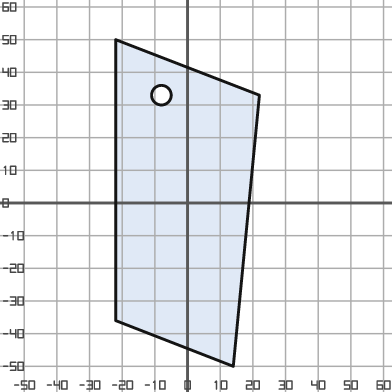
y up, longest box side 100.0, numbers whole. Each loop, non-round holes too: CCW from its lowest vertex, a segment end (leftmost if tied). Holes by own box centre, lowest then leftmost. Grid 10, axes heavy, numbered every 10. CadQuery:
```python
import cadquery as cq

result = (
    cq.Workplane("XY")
    .moveTo(14.0, -50.0)
    .lineTo(22.0, 33.0)
    .lineTo(-22.0, 50.0)
    .lineTo(-22.0, -36.0)
    .close()
    .moveTo(-8.0, 33.0)
    .circle(3.0)
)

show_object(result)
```